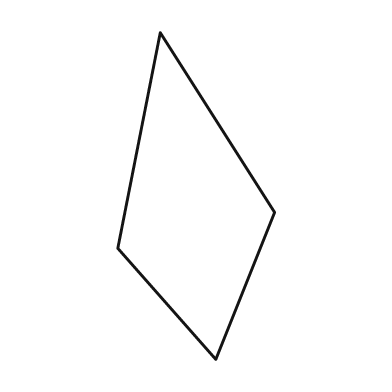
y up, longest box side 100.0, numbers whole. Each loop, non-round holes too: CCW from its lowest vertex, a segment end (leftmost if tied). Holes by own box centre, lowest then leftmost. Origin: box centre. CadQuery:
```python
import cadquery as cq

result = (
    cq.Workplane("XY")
    .moveTo(6.0, -50.0)
    .lineTo(24.0, -5.0)
    .lineTo(-11.0, 50.0)
    .lineTo(-24.0, -16.0)
    .close()
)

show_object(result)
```